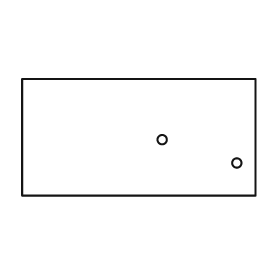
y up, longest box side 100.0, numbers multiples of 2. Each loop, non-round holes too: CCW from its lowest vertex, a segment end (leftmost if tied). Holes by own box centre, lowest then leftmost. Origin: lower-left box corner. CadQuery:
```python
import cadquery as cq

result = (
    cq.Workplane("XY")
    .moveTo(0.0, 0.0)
    .lineTo(100.0, 0.0)
    .lineTo(100.0, 50.0)
    .lineTo(0.0, 50.0)
    .close()
    .moveTo(92.0, 14.0)
    .circle(2.0)
    .moveTo(60.0, 24.0)
    .circle(2.0)
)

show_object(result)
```